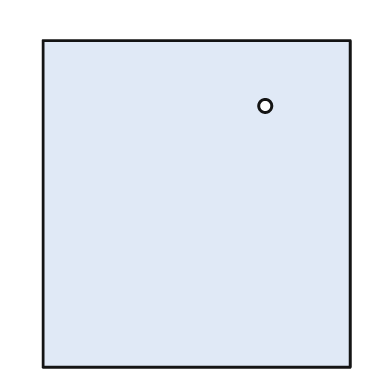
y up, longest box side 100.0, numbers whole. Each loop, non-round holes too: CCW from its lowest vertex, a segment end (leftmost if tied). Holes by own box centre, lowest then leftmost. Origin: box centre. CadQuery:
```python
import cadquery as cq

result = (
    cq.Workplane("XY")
    .moveTo(-47.0, -50.0)
    .lineTo(47.0, -50.0)
    .lineTo(47.0, 50.0)
    .lineTo(-47.0, 50.0)
    .close()
    .moveTo(21.0, 30.0)
    .circle(2.0)
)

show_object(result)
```